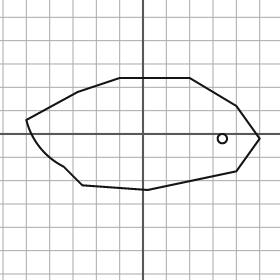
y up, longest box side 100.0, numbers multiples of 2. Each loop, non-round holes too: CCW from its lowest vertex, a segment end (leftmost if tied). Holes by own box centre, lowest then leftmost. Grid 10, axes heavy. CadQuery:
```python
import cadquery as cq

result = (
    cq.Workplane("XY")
    .moveTo(2.0, -24.0)
    .lineTo(40.0, -16.0)
    .lineTo(50.0, -2.0)
    .lineTo(40.0, 12.0)
    .lineTo(20.0, 24.0)
    .lineTo(-10.0, 24.0)
    .lineTo(-28.0, 18.0)
    .lineTo(-50.0, 6.0)
    .threePointArc((-44.0, -6.0), (-34.0, -14.0))
    .lineTo(-26.0, -22.0)
    .close()
    .moveTo(34.0, -2.0)
    .circle(2.0)
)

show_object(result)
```